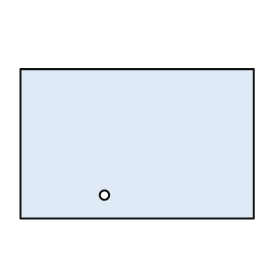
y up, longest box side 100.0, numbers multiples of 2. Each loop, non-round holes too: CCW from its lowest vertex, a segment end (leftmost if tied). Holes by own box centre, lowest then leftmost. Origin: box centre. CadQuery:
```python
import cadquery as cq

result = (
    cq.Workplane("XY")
    .moveTo(-50.0, -32.0)
    .lineTo(50.0, -32.0)
    .lineTo(50.0, 32.0)
    .lineTo(-50.0, 32.0)
    .close()
    .moveTo(-14.0, -22.0)
    .circle(2.0)
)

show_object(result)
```